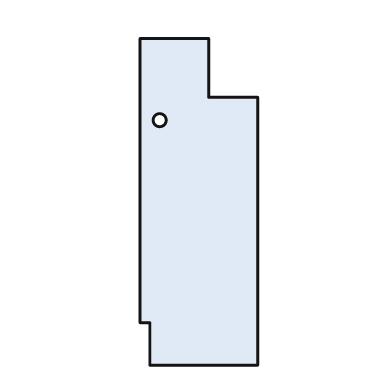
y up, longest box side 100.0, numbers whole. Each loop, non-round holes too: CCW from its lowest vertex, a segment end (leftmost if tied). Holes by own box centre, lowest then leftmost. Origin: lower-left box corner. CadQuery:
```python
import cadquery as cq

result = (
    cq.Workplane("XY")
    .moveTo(3.0, 0.0)
    .lineTo(36.0, 0.0)
    .lineTo(36.0, 82.0)
    .lineTo(21.0, 82.0)
    .lineTo(21.0, 100.0)
    .lineTo(0.0, 100.0)
    .lineTo(0.0, 13.0)
    .lineTo(3.0, 13.0)
    .close()
    .moveTo(6.0, 75.0)
    .circle(2.0)
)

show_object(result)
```